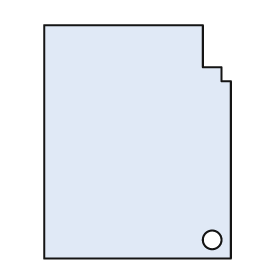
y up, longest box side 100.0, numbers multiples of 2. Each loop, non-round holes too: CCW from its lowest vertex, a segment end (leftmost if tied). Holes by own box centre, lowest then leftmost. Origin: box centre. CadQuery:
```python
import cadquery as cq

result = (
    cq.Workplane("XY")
    .moveTo(-40.0, -50.0)
    .lineTo(40.0, -50.0)
    .lineTo(40.0, 26.0)
    .lineTo(36.0, 26.0)
    .lineTo(36.0, 32.0)
    .lineTo(28.0, 32.0)
    .lineTo(28.0, 50.0)
    .lineTo(-40.0, 50.0)
    .close()
    .moveTo(32.0, -42.0)
    .circle(4.0)
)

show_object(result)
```